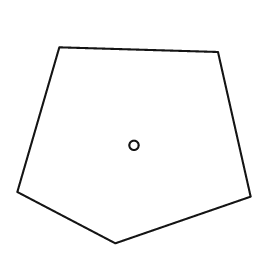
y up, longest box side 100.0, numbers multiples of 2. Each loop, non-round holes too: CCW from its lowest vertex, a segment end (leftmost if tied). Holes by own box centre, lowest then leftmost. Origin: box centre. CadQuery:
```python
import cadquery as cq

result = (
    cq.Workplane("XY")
    .moveTo(-8.0, -42.0)
    .lineTo(50.0, -22.0)
    .lineTo(36.0, 40.0)
    .lineTo(-32.0, 42.0)
    .lineTo(-50.0, -20.0)
    .close()
    .moveTo(0.0, 0.0)
    .circle(2.0)
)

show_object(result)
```